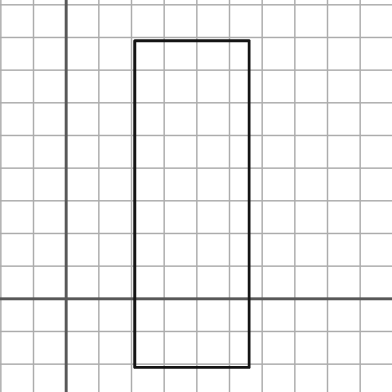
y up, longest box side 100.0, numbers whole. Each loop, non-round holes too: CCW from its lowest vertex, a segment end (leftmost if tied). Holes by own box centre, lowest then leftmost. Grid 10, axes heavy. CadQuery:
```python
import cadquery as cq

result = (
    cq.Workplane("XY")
    .moveTo(21.0, -21.0)
    .lineTo(56.0, -21.0)
    .lineTo(56.0, 79.0)
    .lineTo(21.0, 79.0)
    .close()
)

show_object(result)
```